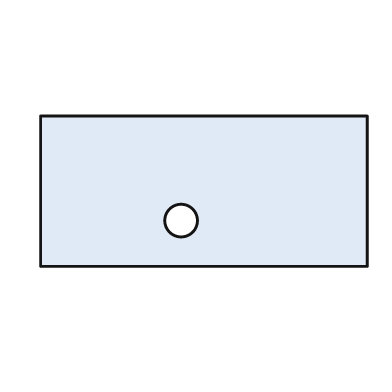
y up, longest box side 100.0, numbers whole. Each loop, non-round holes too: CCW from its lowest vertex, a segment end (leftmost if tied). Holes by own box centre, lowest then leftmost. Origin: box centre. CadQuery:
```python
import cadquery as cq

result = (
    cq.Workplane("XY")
    .moveTo(-50.0, -23.0)
    .lineTo(50.0, -23.0)
    .lineTo(50.0, 23.0)
    .lineTo(-50.0, 23.0)
    .close()
    .moveTo(-7.0, -9.0)
    .circle(5.0)
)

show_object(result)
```